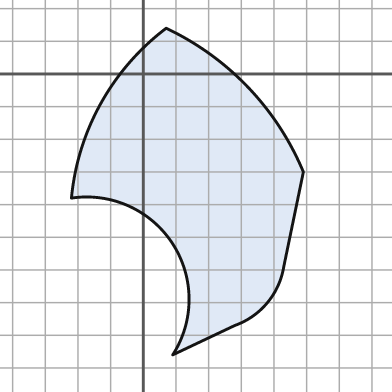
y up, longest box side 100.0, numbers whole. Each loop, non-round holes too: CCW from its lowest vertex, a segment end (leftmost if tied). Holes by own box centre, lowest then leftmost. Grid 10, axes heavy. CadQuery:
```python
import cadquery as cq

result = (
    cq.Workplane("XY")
    .moveTo(9.0, -86.0)
    .lineTo(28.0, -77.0)
    .threePointArc((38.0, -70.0), (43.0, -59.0))
    .lineTo(49.0, -30.0)
    .threePointArc((32.0, -4.0), (7.0, 14.0))
    .threePointArc((-13.0, -9.0), (-22.0, -38.0))
    .threePointArc((9.0, -52.0), (9.0, -86.0))
    .close()
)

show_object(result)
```